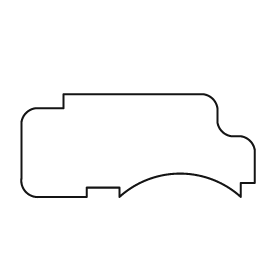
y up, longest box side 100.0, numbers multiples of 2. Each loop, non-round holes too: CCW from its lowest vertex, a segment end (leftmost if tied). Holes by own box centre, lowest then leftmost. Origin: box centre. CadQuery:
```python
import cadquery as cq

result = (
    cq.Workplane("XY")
    .moveTo(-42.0, -22.0)
    .lineTo(-22.0, -22.0)
    .lineTo(-22.0, -18.0)
    .lineTo(-8.0, -18.0)
    .lineTo(-8.0, -22.0)
    .threePointArc((18.0, -12.0), (44.0, -22.0))
    .lineTo(44.0, -16.0)
    .lineTo(50.0, -16.0)
    .lineTo(50.0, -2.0)
    .threePointArc((48.0, 2.0), (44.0, 4.0))
    .lineTo(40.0, 4.0)
    .threePointArc((36.0, 6.0), (34.0, 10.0))
    .lineTo(34.0, 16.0)
    .threePointArc((32.0, 20.0), (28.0, 22.0))
    .lineTo(-32.0, 22.0)
    .lineTo(-32.0, 16.0)
    .lineTo(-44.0, 16.0)
    .threePointArc((-48.0, 14.0), (-50.0, 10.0))
    .lineTo(-50.0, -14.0)
    .threePointArc((-48.0, -20.0), (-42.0, -22.0))
    .close()
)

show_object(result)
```